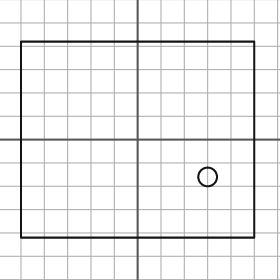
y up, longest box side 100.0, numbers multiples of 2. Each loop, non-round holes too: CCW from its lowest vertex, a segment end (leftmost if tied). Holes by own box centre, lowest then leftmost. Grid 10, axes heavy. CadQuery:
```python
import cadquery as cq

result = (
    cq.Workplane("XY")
    .moveTo(-50.0, -42.0)
    .lineTo(50.0, -42.0)
    .lineTo(50.0, 42.0)
    .lineTo(-50.0, 42.0)
    .close()
    .moveTo(30.0, -16.0)
    .circle(4.0)
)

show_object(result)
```